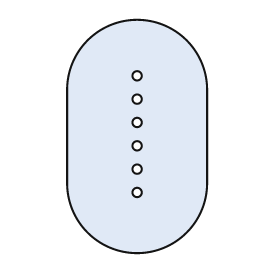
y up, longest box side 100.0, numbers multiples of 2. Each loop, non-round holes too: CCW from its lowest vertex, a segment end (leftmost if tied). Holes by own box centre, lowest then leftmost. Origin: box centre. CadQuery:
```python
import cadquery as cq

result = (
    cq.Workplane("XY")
    .moveTo(-30.0, -20.0)
    .threePointArc((0.0, -50.0), (30.0, -20.0))
    .lineTo(30.0, 20.0)
    .threePointArc((0.0, 50.0), (-30.0, 20.0))
    .close()
    .moveTo(0.0, -24.0)
    .circle(2.0)
    .moveTo(0.0, -14.0)
    .circle(2.0)
    .moveTo(0.0, -4.0)
    .circle(2.0)
    .moveTo(0.0, 6.0)
    .circle(2.0)
    .moveTo(0.0, 16.0)
    .circle(2.0)
    .moveTo(0.0, 26.0)
    .circle(2.0)
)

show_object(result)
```